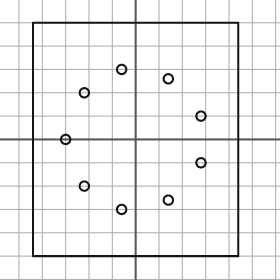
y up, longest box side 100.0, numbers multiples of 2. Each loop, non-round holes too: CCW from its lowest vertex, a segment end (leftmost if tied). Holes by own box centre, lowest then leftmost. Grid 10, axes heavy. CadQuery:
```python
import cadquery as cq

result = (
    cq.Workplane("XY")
    .moveTo(-44.0, -50.0)
    .lineTo(44.0, -50.0)
    .lineTo(44.0, 50.0)
    .lineTo(-44.0, 50.0)
    .close()
    .moveTo(-6.0, -30.0)
    .circle(2.0)
    .moveTo(14.0, -26.0)
    .circle(2.0)
    .moveTo(-22.0, -20.0)
    .circle(2.0)
    .moveTo(28.0, -10.0)
    .circle(2.0)
    .moveTo(-30.0, 0.0)
    .circle(2.0)
    .moveTo(28.0, 10.0)
    .circle(2.0)
    .moveTo(-22.0, 20.0)
    .circle(2.0)
    .moveTo(14.0, 26.0)
    .circle(2.0)
    .moveTo(-6.0, 30.0)
    .circle(2.0)
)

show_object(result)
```